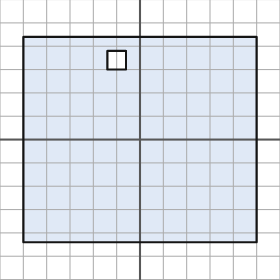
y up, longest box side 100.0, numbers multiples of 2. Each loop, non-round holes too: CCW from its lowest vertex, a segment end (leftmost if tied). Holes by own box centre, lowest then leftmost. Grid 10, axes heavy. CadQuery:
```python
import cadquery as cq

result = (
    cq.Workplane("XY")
    .moveTo(-50.0, -44.0)
    .lineTo(50.0, -44.0)
    .lineTo(50.0, 44.0)
    .lineTo(-50.0, 44.0)
    .close()
    .moveTo(-14.0, 30.0)
    .lineTo(-6.0, 30.0)
    .lineTo(-6.0, 38.0)
    .lineTo(-14.0, 38.0)
    .close()
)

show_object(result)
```